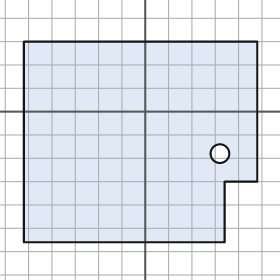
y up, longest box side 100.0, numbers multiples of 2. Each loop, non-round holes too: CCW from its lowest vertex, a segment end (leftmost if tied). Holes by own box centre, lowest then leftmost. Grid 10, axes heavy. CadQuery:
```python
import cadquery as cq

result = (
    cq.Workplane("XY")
    .moveTo(-52.0, -56.0)
    .lineTo(34.0, -56.0)
    .lineTo(34.0, -30.0)
    .lineTo(48.0, -30.0)
    .lineTo(48.0, 30.0)
    .lineTo(-52.0, 30.0)
    .close()
    .moveTo(32.0, -18.0)
    .circle(4.0)
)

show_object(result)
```